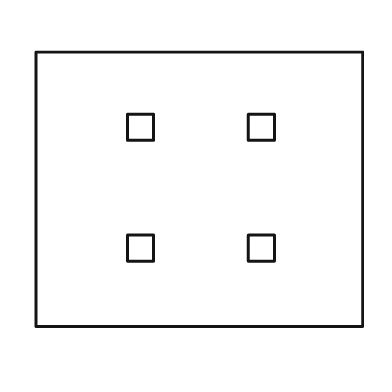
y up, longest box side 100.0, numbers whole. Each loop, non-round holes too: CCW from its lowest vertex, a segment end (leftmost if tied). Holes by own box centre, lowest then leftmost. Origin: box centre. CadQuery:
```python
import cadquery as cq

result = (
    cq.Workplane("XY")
    .moveTo(-50.0, -42.0)
    .lineTo(50.0, -42.0)
    .lineTo(50.0, 42.0)
    .lineTo(-50.0, 42.0)
    .close()
    .moveTo(-22.0, -22.0)
    .lineTo(-14.0, -22.0)
    .lineTo(-14.0, -14.0)
    .lineTo(-22.0, -14.0)
    .close()
    .moveTo(15.0, -22.0)
    .lineTo(23.0, -22.0)
    .lineTo(23.0, -14.0)
    .lineTo(15.0, -14.0)
    .close()
    .moveTo(-22.0, 15.0)
    .lineTo(-14.0, 15.0)
    .lineTo(-14.0, 23.0)
    .lineTo(-22.0, 23.0)
    .close()
    .moveTo(15.0, 15.0)
    .lineTo(23.0, 15.0)
    .lineTo(23.0, 23.0)
    .lineTo(15.0, 23.0)
    .close()
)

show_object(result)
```